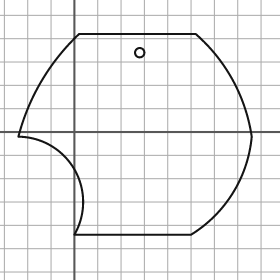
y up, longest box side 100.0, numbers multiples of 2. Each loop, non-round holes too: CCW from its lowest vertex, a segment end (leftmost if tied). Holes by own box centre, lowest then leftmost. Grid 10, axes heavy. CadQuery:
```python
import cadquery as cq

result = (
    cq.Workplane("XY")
    .moveTo(0.0, -44.0)
    .lineTo(50.0, -44.0)
    .threePointArc((68.0, -26.0), (76.0, -2.0))
    .threePointArc((68.0, 22.0), (52.0, 42.0))
    .lineTo(2.0, 42.0)
    .threePointArc((-14.0, 22.0), (-24.0, -2.0))
    .threePointArc((0.0, -16.0), (0.0, -44.0))
    .close()
    .moveTo(28.0, 34.0)
    .circle(2.0)
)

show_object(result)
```